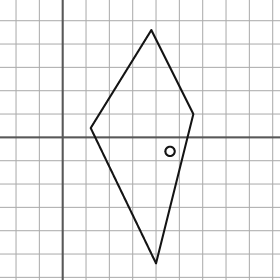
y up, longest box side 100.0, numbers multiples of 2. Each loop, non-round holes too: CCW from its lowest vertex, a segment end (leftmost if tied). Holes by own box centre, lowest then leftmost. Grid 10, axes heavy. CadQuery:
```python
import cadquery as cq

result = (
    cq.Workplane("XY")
    .moveTo(40.0, -54.0)
    .lineTo(56.0, 10.0)
    .lineTo(38.0, 46.0)
    .lineTo(12.0, 4.0)
    .close()
    .moveTo(46.0, -6.0)
    .circle(2.0)
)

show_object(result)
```